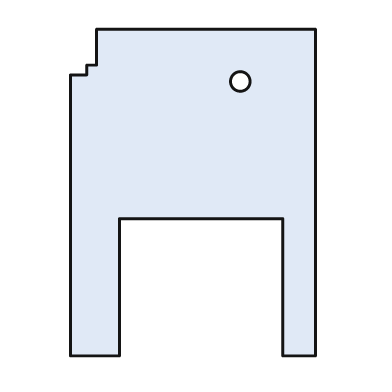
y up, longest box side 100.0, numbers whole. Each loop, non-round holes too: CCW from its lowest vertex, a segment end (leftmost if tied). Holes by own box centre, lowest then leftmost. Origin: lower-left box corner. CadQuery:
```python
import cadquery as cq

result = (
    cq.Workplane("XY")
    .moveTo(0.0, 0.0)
    .lineTo(15.0, 0.0)
    .lineTo(15.0, 42.0)
    .lineTo(65.0, 42.0)
    .lineTo(65.0, 0.0)
    .lineTo(75.0, 0.0)
    .lineTo(75.0, 100.0)
    .lineTo(8.0, 100.0)
    .lineTo(8.0, 89.0)
    .lineTo(5.0, 89.0)
    .lineTo(5.0, 86.0)
    .lineTo(0.0, 86.0)
    .close()
    .moveTo(52.0, 84.0)
    .circle(3.0)
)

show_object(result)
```